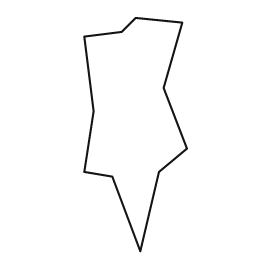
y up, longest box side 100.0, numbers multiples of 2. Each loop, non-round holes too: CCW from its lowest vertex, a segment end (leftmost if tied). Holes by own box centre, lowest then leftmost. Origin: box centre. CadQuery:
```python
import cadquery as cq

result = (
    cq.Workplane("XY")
    .moveTo(2.0, -50.0)
    .lineTo(10.0, -16.0)
    .lineTo(22.0, -6.0)
    .lineTo(12.0, 20.0)
    .lineTo(20.0, 48.0)
    .lineTo(0.0, 50.0)
    .lineTo(-6.0, 44.0)
    .lineTo(-22.0, 42.0)
    .lineTo(-18.0, 10.0)
    .lineTo(-22.0, -16.0)
    .lineTo(-10.0, -18.0)
    .close()
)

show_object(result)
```